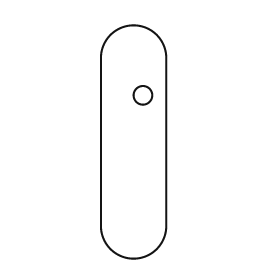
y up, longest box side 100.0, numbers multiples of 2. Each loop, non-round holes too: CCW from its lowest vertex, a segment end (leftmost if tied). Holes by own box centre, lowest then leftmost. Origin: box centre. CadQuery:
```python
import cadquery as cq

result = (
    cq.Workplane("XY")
    .moveTo(-14.0, -36.0)
    .threePointArc((0.0, -50.0), (14.0, -36.0))
    .lineTo(14.0, 36.0)
    .threePointArc((0.0, 50.0), (-14.0, 36.0))
    .close()
    .moveTo(4.0, 20.0)
    .circle(4.0)
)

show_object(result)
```